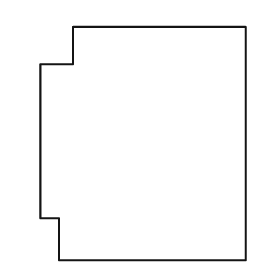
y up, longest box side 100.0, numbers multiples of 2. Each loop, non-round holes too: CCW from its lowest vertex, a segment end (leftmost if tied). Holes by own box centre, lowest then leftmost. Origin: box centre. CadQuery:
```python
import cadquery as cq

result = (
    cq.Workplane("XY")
    .moveTo(-36.0, -50.0)
    .lineTo(44.0, -50.0)
    .lineTo(44.0, 50.0)
    .lineTo(-30.0, 50.0)
    .lineTo(-30.0, 34.0)
    .lineTo(-44.0, 34.0)
    .lineTo(-44.0, -32.0)
    .lineTo(-36.0, -32.0)
    .close()
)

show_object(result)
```